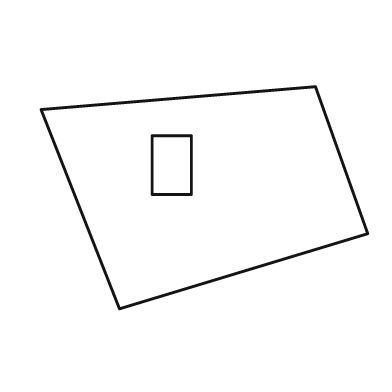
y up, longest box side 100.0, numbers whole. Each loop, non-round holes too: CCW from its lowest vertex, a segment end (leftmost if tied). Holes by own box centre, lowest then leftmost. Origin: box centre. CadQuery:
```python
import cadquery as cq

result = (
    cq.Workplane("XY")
    .moveTo(-26.0, -34.0)
    .lineTo(50.0, -11.0)
    .lineTo(34.0, 34.0)
    .lineTo(-50.0, 27.0)
    .close()
    .moveTo(-16.0, 1.0)
    .lineTo(-4.0, 1.0)
    .lineTo(-4.0, 19.0)
    .lineTo(-16.0, 19.0)
    .close()
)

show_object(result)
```